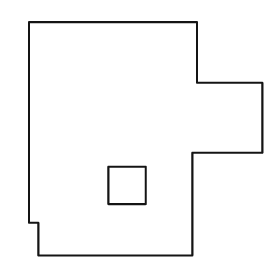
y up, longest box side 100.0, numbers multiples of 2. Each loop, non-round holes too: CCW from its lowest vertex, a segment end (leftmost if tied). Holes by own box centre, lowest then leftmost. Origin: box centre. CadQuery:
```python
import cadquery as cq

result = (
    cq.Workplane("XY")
    .moveTo(-46.0, -50.0)
    .lineTo(20.0, -50.0)
    .lineTo(20.0, -6.0)
    .lineTo(50.0, -6.0)
    .lineTo(50.0, 24.0)
    .lineTo(22.0, 24.0)
    .lineTo(22.0, 50.0)
    .lineTo(-50.0, 50.0)
    .lineTo(-50.0, -36.0)
    .lineTo(-46.0, -36.0)
    .close()
    .moveTo(-16.0, -28.0)
    .lineTo(0.0, -28.0)
    .lineTo(0.0, -12.0)
    .lineTo(-16.0, -12.0)
    .close()
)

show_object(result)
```